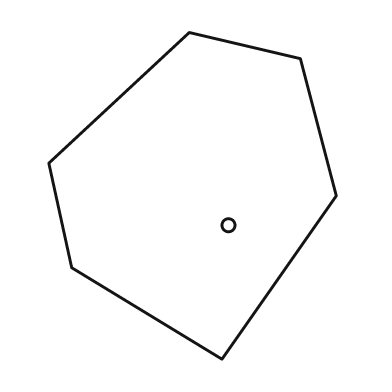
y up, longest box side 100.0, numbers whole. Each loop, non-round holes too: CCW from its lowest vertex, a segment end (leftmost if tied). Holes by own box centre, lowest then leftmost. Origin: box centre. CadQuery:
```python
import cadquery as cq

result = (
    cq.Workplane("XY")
    .moveTo(9.0, -50.0)
    .lineTo(44.0, 0.0)
    .lineTo(33.0, 42.0)
    .lineTo(-1.0, 50.0)
    .lineTo(-44.0, 10.0)
    .lineTo(-37.0, -22.0)
    .close()
    .moveTo(11.0, -9.0)
    .circle(2.0)
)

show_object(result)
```